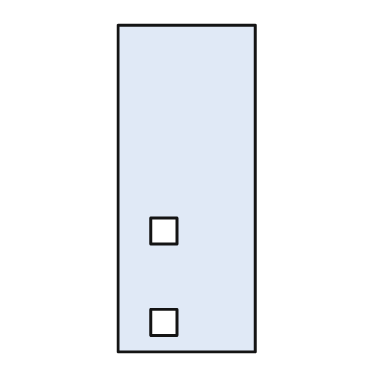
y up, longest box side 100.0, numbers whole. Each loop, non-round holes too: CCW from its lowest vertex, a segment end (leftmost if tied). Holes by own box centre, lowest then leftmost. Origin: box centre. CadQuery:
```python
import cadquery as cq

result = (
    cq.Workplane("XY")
    .moveTo(-21.0, -50.0)
    .lineTo(21.0, -50.0)
    .lineTo(21.0, 50.0)
    .lineTo(-21.0, 50.0)
    .close()
    .moveTo(-11.0, -45.0)
    .lineTo(-3.0, -45.0)
    .lineTo(-3.0, -37.0)
    .lineTo(-11.0, -37.0)
    .close()
    .moveTo(-11.0, -17.0)
    .lineTo(-3.0, -17.0)
    .lineTo(-3.0, -9.0)
    .lineTo(-11.0, -9.0)
    .close()
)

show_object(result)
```